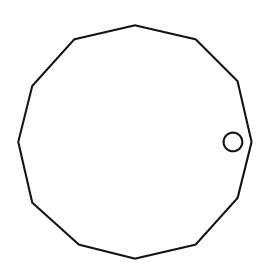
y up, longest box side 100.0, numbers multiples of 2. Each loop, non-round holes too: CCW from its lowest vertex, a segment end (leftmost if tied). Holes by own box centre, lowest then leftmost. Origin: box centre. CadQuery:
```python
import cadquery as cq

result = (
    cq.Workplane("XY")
    .moveTo(0.0, -50.0)
    .lineTo(26.0, -44.0)
    .lineTo(44.0, -24.0)
    .lineTo(50.0, 0.0)
    .lineTo(44.0, 26.0)
    .lineTo(26.0, 44.0)
    .lineTo(0.0, 50.0)
    .lineTo(-26.0, 44.0)
    .lineTo(-44.0, 24.0)
    .lineTo(-50.0, 0.0)
    .lineTo(-44.0, -26.0)
    .lineTo(-24.0, -44.0)
    .close()
    .moveTo(42.0, 0.0)
    .circle(4.0)
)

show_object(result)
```